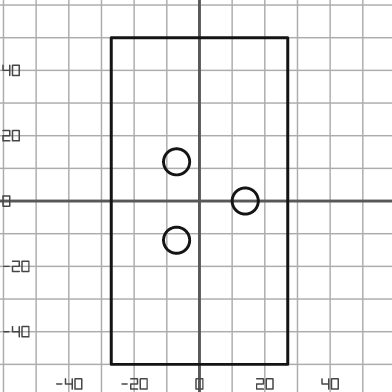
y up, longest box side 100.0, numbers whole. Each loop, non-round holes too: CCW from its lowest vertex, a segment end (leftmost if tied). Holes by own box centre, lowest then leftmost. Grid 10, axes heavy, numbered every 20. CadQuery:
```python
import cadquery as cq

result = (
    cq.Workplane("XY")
    .moveTo(-27.0, -50.0)
    .lineTo(27.0, -50.0)
    .lineTo(27.0, 50.0)
    .lineTo(-27.0, 50.0)
    .close()
    .moveTo(-7.0, -12.0)
    .circle(4.0)
    .moveTo(14.0, 0.0)
    .circle(4.0)
    .moveTo(-7.0, 12.0)
    .circle(4.0)
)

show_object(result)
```